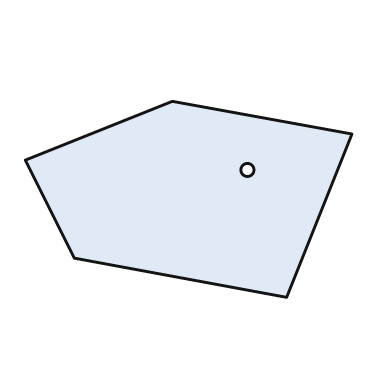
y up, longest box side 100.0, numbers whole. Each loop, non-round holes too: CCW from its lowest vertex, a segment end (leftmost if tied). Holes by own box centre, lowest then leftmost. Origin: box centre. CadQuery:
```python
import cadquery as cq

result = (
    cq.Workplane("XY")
    .moveTo(30.0, -30.0)
    .lineTo(50.0, 20.0)
    .lineTo(-5.0, 30.0)
    .lineTo(-50.0, 12.0)
    .lineTo(-35.0, -18.0)
    .close()
    .moveTo(18.0, 9.0)
    .circle(2.0)
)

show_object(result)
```